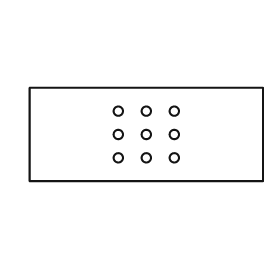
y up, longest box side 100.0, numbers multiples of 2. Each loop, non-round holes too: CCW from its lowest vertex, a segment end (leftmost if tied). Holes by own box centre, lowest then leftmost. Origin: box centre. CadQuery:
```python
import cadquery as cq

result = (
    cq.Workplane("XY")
    .moveTo(-50.0, -20.0)
    .lineTo(50.0, -20.0)
    .lineTo(50.0, 20.0)
    .lineTo(-50.0, 20.0)
    .close()
    .moveTo(-12.0, -10.0)
    .circle(2.0)
    .moveTo(0.0, -10.0)
    .circle(2.0)
    .moveTo(12.0, -10.0)
    .circle(2.0)
    .moveTo(-12.0, 0.0)
    .circle(2.0)
    .moveTo(0.0, 0.0)
    .circle(2.0)
    .moveTo(12.0, 0.0)
    .circle(2.0)
    .moveTo(-12.0, 10.0)
    .circle(2.0)
    .moveTo(0.0, 10.0)
    .circle(2.0)
    .moveTo(12.0, 10.0)
    .circle(2.0)
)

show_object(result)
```